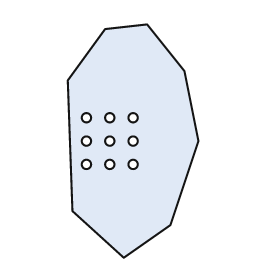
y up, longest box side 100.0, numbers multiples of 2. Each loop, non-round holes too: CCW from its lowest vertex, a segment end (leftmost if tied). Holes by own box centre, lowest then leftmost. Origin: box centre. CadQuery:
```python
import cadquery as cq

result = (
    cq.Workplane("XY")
    .moveTo(-4.0, -50.0)
    .lineTo(16.0, -36.0)
    .lineTo(28.0, 0.0)
    .lineTo(22.0, 30.0)
    .lineTo(6.0, 50.0)
    .lineTo(-12.0, 48.0)
    .lineTo(-28.0, 26.0)
    .lineTo(-26.0, -30.0)
    .close()
    .moveTo(-20.0, -10.0)
    .circle(2.0)
    .moveTo(-10.0, -10.0)
    .circle(2.0)
    .moveTo(0.0, -10.0)
    .circle(2.0)
    .moveTo(-20.0, 0.0)
    .circle(2.0)
    .moveTo(-10.0, 0.0)
    .circle(2.0)
    .moveTo(0.0, 0.0)
    .circle(2.0)
    .moveTo(-20.0, 10.0)
    .circle(2.0)
    .moveTo(-10.0, 10.0)
    .circle(2.0)
    .moveTo(0.0, 10.0)
    .circle(2.0)
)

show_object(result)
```